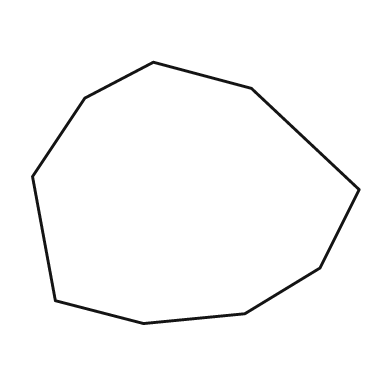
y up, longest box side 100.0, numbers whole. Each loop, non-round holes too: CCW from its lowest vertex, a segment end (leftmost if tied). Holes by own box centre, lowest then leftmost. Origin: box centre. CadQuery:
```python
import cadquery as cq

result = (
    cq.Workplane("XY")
    .moveTo(-16.0, -40.0)
    .lineTo(15.0, -37.0)
    .lineTo(38.0, -23.0)
    .lineTo(50.0, 1.0)
    .lineTo(17.0, 32.0)
    .lineTo(-13.0, 40.0)
    .lineTo(-34.0, 29.0)
    .lineTo(-50.0, 5.0)
    .lineTo(-43.0, -33.0)
    .close()
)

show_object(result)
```